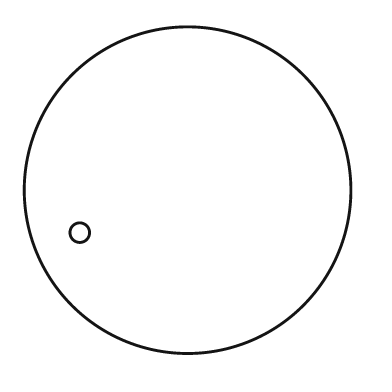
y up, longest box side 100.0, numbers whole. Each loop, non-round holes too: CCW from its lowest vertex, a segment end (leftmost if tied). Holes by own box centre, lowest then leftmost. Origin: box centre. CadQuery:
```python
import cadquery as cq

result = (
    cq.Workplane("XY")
    .moveTo(0.0, 0.0)
    .circle(50.0)
    .moveTo(-33.0, -13.0)
    .circle(3.0)
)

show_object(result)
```